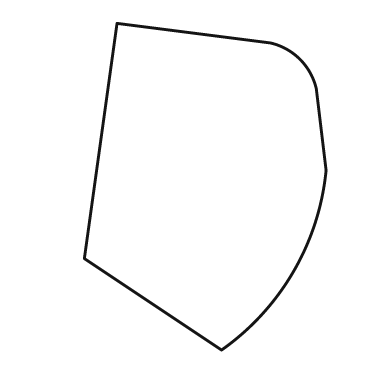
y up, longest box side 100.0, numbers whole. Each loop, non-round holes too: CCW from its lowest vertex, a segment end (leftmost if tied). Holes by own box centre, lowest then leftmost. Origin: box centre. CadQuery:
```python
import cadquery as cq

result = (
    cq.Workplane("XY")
    .moveTo(5.0, -50.0)
    .threePointArc((27.0, -26.0), (37.0, 5.0))
    .lineTo(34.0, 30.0)
    .threePointArc((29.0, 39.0), (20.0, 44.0))
    .lineTo(-27.0, 50.0)
    .lineTo(-37.0, -22.0)
    .close()
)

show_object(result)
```